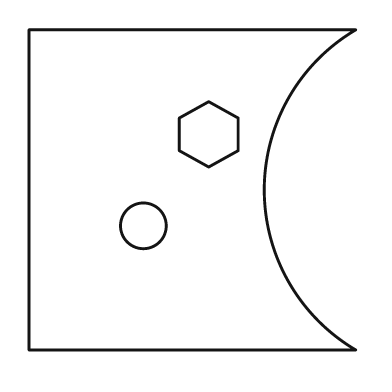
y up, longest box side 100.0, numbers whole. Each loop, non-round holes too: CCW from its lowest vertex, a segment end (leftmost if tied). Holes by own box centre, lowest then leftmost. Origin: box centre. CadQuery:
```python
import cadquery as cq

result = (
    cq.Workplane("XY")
    .moveTo(-50.0, -49.0)
    .lineTo(50.0, -49.0)
    .threePointArc((22.0, 0.0), (50.0, 49.0))
    .lineTo(-50.0, 49.0)
    .close()
    .moveTo(-15.0, -11.0)
    .circle(7.0)
    .moveTo(5.0, 7.0)
    .lineTo(14.0, 12.0)
    .lineTo(14.0, 22.0)
    .lineTo(5.0, 27.0)
    .lineTo(-4.0, 22.0)
    .lineTo(-4.0, 12.0)
    .close()
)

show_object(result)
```